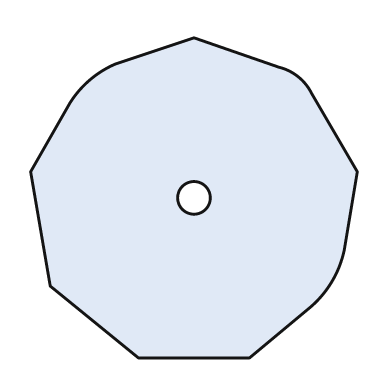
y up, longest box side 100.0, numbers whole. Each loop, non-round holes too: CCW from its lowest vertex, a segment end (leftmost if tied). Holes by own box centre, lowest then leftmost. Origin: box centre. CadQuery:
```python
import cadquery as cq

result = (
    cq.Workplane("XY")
    .moveTo(-17.0, -49.0)
    .lineTo(17.0, -49.0)
    .lineTo(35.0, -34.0)
    .threePointArc((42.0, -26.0), (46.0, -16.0))
    .lineTo(50.0, 8.0)
    .lineTo(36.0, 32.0)
    .threePointArc((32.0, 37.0), (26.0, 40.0))
    .lineTo(0.0, 49.0)
    .lineTo(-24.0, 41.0)
    .threePointArc((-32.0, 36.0), (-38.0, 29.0))
    .lineTo(-50.0, 8.0)
    .lineTo(-44.0, -27.0)
    .close()
    .moveTo(0.0, 0.0)
    .circle(5.0)
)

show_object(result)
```